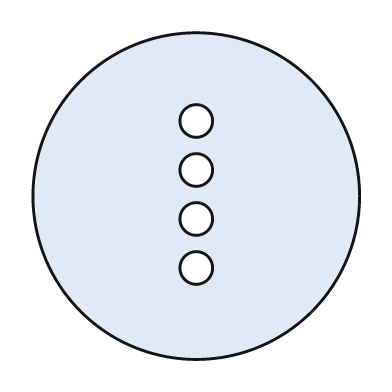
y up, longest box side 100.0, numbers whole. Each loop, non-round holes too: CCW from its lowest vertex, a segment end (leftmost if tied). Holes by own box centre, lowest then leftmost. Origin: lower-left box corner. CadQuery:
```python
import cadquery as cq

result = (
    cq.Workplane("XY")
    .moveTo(50.0, 50.0)
    .circle(50.0)
    .moveTo(50.0, 28.0)
    .circle(5.0)
    .moveTo(50.0, 43.0)
    .circle(5.0)
    .moveTo(50.0, 58.0)
    .circle(5.0)
    .moveTo(50.0, 73.0)
    .circle(5.0)
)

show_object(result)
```